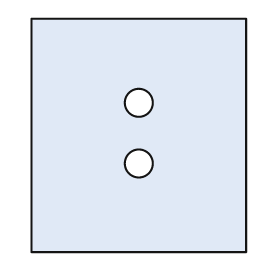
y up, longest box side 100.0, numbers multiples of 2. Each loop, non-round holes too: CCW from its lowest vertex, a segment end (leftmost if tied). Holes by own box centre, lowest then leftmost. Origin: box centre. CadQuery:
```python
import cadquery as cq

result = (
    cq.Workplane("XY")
    .moveTo(-46.0, -50.0)
    .lineTo(46.0, -50.0)
    .lineTo(46.0, 50.0)
    .lineTo(-46.0, 50.0)
    .close()
    .moveTo(0.0, -12.0)
    .circle(6.0)
    .moveTo(0.0, 14.0)
    .circle(6.0)
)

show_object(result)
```